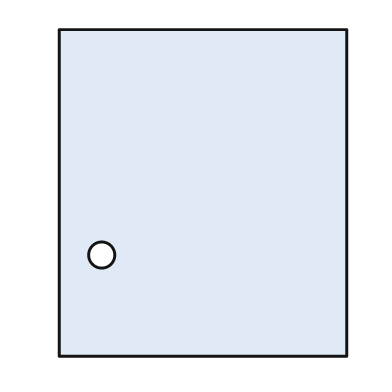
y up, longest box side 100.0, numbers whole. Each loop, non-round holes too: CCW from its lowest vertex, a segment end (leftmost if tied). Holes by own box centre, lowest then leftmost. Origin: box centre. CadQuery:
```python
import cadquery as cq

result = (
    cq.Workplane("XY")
    .moveTo(-44.0, -50.0)
    .lineTo(44.0, -50.0)
    .lineTo(44.0, 50.0)
    .lineTo(-44.0, 50.0)
    .close()
    .moveTo(-31.0, -19.0)
    .circle(4.0)
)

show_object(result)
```